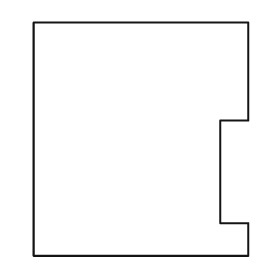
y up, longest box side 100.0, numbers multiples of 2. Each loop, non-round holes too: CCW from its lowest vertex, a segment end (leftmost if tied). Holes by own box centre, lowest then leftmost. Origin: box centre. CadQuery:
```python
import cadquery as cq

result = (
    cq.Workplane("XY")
    .moveTo(-46.0, -50.0)
    .lineTo(46.0, -50.0)
    .lineTo(46.0, -36.0)
    .lineTo(34.0, -36.0)
    .lineTo(34.0, 8.0)
    .lineTo(46.0, 8.0)
    .lineTo(46.0, 50.0)
    .lineTo(-46.0, 50.0)
    .close()
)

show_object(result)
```